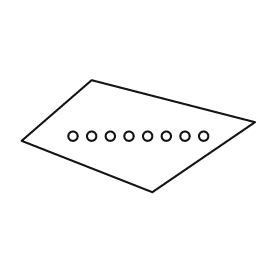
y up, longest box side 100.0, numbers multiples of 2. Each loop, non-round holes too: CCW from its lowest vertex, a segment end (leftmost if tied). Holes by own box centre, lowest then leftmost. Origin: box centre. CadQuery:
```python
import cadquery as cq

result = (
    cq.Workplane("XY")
    .moveTo(6.0, -24.0)
    .lineTo(50.0, 6.0)
    .lineTo(-20.0, 24.0)
    .lineTo(-50.0, -2.0)
    .close()
    .moveTo(-28.0, 0.0)
    .circle(2.0)
    .moveTo(-20.0, 0.0)
    .circle(2.0)
    .moveTo(-12.0, 0.0)
    .circle(2.0)
    .moveTo(-4.0, 0.0)
    .circle(2.0)
    .moveTo(4.0, 0.0)
    .circle(2.0)
    .moveTo(12.0, 0.0)
    .circle(2.0)
    .moveTo(20.0, 0.0)
    .circle(2.0)
    .moveTo(28.0, 0.0)
    .circle(2.0)
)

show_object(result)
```